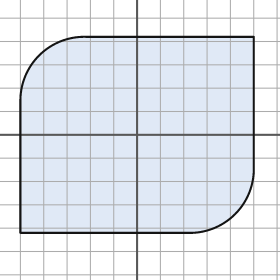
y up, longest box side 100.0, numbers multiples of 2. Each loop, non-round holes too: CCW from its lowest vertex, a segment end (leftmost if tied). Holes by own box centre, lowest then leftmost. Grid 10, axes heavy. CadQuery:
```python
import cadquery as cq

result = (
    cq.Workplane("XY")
    .moveTo(-50.0, -42.0)
    .lineTo(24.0, -42.0)
    .threePointArc((42.0, -34.0), (50.0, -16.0))
    .lineTo(50.0, 42.0)
    .lineTo(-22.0, 42.0)
    .threePointArc((-42.0, 34.0), (-50.0, 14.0))
    .close()
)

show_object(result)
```